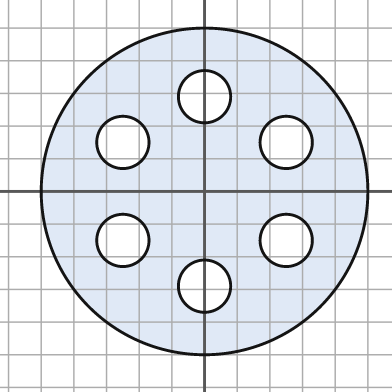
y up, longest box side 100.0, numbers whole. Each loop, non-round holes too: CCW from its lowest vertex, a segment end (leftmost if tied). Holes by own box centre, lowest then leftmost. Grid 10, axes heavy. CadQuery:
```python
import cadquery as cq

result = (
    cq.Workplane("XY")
    .moveTo(0.0, 0.0)
    .circle(50.0)
    .moveTo(0.0, -29.0)
    .circle(8.0)
    .moveTo(-25.0, -15.0)
    .circle(8.0)
    .moveTo(25.0, -15.0)
    .circle(8.0)
    .moveTo(-25.0, 15.0)
    .circle(8.0)
    .moveTo(25.0, 15.0)
    .circle(8.0)
    .moveTo(0.0, 29.0)
    .circle(8.0)
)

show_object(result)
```